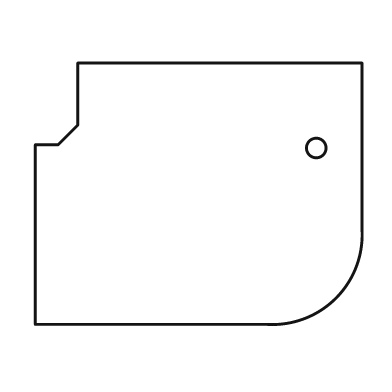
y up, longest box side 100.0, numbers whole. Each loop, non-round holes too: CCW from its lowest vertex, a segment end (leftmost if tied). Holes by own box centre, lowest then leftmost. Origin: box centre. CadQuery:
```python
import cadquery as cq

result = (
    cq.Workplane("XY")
    .moveTo(-50.0, -40.0)
    .lineTo(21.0, -40.0)
    .threePointArc((42.0, -32.0), (50.0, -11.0))
    .lineTo(50.0, 40.0)
    .lineTo(-37.0, 40.0)
    .lineTo(-37.0, 21.0)
    .lineTo(-43.0, 15.0)
    .lineTo(-50.0, 15.0)
    .close()
    .moveTo(36.0, 14.0)
    .circle(3.0)
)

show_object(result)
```